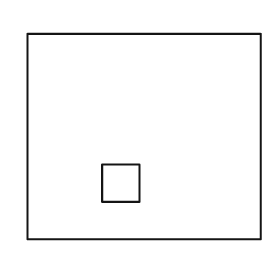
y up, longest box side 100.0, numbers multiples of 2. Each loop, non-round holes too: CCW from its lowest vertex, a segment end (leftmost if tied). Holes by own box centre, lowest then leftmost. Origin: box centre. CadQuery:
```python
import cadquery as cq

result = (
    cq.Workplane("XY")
    .moveTo(-50.0, -44.0)
    .lineTo(50.0, -44.0)
    .lineTo(50.0, 44.0)
    .lineTo(-50.0, 44.0)
    .close()
    .moveTo(-18.0, -28.0)
    .lineTo(-2.0, -28.0)
    .lineTo(-2.0, -12.0)
    .lineTo(-18.0, -12.0)
    .close()
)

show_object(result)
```